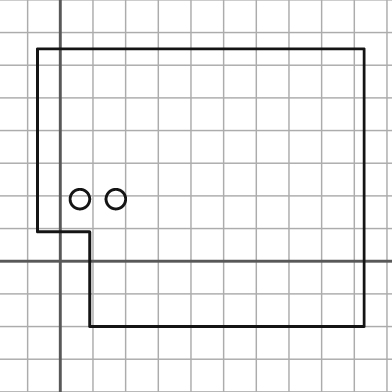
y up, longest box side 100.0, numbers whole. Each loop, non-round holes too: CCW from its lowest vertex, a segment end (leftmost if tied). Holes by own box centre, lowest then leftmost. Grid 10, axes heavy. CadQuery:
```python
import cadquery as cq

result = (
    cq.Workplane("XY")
    .moveTo(9.0, -20.0)
    .lineTo(93.0, -20.0)
    .lineTo(93.0, 65.0)
    .lineTo(-7.0, 65.0)
    .lineTo(-7.0, 9.0)
    .lineTo(9.0, 9.0)
    .close()
    .moveTo(6.0, 19.0)
    .circle(3.0)
    .moveTo(17.0, 19.0)
    .circle(3.0)
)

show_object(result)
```